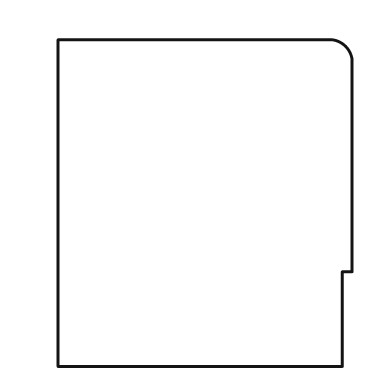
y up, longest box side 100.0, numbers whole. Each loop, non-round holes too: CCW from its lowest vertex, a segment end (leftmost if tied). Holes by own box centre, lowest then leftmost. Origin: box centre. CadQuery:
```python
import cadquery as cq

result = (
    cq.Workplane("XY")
    .moveTo(-45.0, -50.0)
    .lineTo(42.0, -50.0)
    .lineTo(42.0, -21.0)
    .lineTo(45.0, -21.0)
    .lineTo(45.0, 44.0)
    .threePointArc((43.0, 48.0), (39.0, 50.0))
    .lineTo(-45.0, 50.0)
    .close()
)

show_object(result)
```